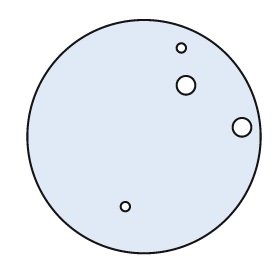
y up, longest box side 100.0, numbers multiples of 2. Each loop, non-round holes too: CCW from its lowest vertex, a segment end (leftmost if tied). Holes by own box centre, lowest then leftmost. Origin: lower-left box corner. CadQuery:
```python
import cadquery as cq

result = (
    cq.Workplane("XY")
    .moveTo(50.0, 50.0)
    .circle(50.0)
    .moveTo(42.0, 20.0)
    .circle(2.0)
    .moveTo(92.0, 54.0)
    .circle(4.0)
    .moveTo(68.0, 72.0)
    .circle(4.0)
    .moveTo(66.0, 88.0)
    .circle(2.0)
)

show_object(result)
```